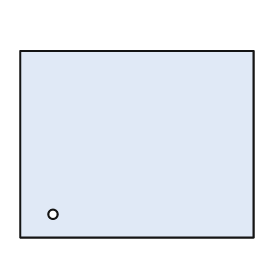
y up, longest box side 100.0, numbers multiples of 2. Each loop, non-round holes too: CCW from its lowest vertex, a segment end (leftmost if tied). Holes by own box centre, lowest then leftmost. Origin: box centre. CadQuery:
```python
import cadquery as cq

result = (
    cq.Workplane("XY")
    .moveTo(-50.0, -40.0)
    .lineTo(50.0, -40.0)
    .lineTo(50.0, 40.0)
    .lineTo(-50.0, 40.0)
    .close()
    .moveTo(-36.0, -30.0)
    .circle(2.0)
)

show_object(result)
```